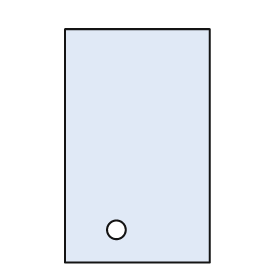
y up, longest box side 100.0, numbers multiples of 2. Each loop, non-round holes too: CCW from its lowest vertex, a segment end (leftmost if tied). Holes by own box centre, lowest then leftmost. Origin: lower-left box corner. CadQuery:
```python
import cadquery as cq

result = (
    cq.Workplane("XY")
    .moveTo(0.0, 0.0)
    .lineTo(62.0, 0.0)
    .lineTo(62.0, 100.0)
    .lineTo(0.0, 100.0)
    .close()
    .moveTo(22.0, 14.0)
    .circle(4.0)
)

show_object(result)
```